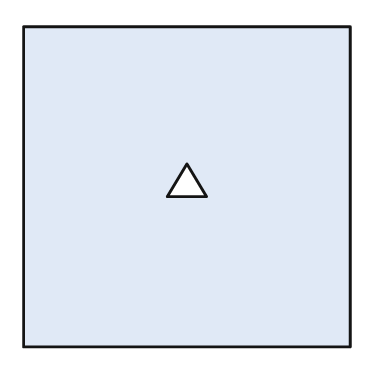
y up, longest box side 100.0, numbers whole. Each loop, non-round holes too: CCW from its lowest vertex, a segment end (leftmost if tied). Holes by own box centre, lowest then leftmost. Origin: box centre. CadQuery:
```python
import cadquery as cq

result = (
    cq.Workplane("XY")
    .moveTo(-50.0, -49.0)
    .lineTo(50.0, -49.0)
    .lineTo(50.0, 49.0)
    .lineTo(-50.0, 49.0)
    .close()
    .moveTo(-6.0, -3.0)
    .lineTo(6.0, -3.0)
    .lineTo(0.0, 7.0)
    .close()
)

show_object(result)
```